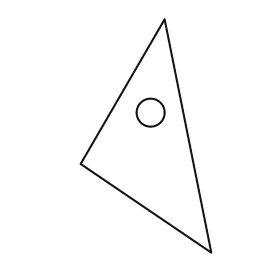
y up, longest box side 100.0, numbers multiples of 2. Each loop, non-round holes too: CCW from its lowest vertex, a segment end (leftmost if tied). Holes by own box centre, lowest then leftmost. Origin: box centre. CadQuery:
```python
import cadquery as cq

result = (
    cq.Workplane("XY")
    .moveTo(28.0, -50.0)
    .lineTo(8.0, 50.0)
    .lineTo(-28.0, -12.0)
    .close()
    .moveTo(2.0, 10.0)
    .circle(6.0)
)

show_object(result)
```